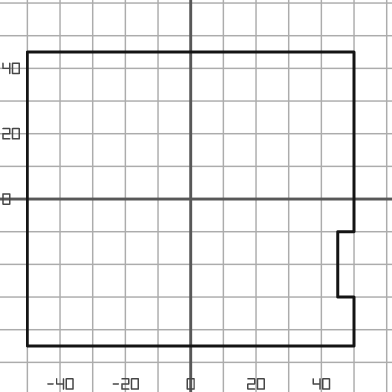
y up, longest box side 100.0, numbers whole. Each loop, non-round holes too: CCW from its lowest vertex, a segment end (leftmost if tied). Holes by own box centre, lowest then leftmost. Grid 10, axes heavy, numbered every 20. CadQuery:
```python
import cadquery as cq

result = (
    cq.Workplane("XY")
    .moveTo(-50.0, -45.0)
    .lineTo(50.0, -45.0)
    .lineTo(50.0, -30.0)
    .lineTo(45.0, -30.0)
    .lineTo(45.0, -10.0)
    .lineTo(50.0, -10.0)
    .lineTo(50.0, 45.0)
    .lineTo(-50.0, 45.0)
    .close()
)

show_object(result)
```